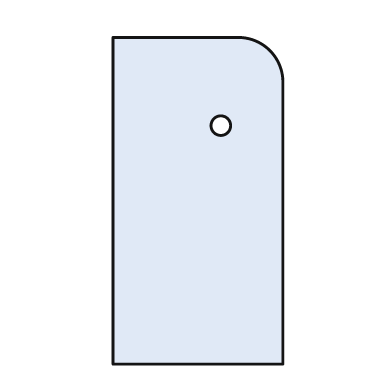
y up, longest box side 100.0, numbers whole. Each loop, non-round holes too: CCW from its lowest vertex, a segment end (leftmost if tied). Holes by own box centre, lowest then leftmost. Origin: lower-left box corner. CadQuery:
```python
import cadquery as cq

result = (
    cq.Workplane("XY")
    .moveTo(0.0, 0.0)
    .lineTo(52.0, 0.0)
    .lineTo(52.0, 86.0)
    .threePointArc((48.0, 96.0), (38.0, 100.0))
    .lineTo(0.0, 100.0)
    .close()
    .moveTo(33.0, 73.0)
    .circle(3.0)
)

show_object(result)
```